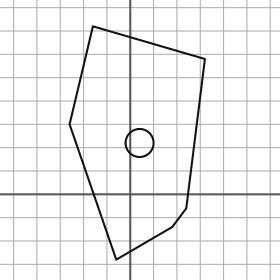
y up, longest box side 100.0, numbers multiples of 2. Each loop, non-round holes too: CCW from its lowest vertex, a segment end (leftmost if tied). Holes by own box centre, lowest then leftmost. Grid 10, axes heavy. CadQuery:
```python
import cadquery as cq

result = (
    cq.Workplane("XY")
    .moveTo(-6.0, -28.0)
    .lineTo(18.0, -14.0)
    .lineTo(24.0, -6.0)
    .lineTo(32.0, 58.0)
    .lineTo(-16.0, 72.0)
    .lineTo(-26.0, 30.0)
    .close()
    .moveTo(4.0, 22.0)
    .circle(6.0)
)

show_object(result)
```